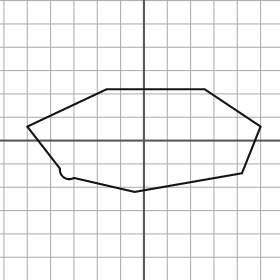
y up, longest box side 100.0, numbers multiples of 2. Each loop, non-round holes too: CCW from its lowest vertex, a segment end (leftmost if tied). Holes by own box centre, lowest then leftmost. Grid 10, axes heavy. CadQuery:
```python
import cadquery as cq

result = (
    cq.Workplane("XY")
    .moveTo(-4.0, -22.0)
    .lineTo(42.0, -14.0)
    .lineTo(50.0, 6.0)
    .lineTo(26.0, 22.0)
    .lineTo(-16.0, 22.0)
    .lineTo(-50.0, 6.0)
    .lineTo(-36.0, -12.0)
    .threePointArc((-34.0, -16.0), (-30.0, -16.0))
    .close()
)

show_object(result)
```